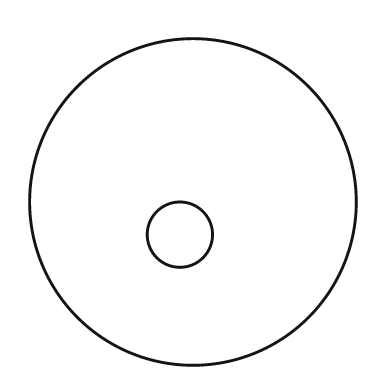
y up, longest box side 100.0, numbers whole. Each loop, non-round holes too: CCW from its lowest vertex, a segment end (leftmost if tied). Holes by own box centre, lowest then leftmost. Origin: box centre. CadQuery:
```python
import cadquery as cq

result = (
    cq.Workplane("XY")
    .moveTo(0.0, 0.0)
    .circle(50.0)
    .moveTo(-4.0, -10.0)
    .circle(10.0)
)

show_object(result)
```